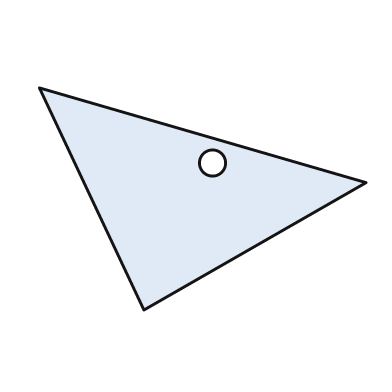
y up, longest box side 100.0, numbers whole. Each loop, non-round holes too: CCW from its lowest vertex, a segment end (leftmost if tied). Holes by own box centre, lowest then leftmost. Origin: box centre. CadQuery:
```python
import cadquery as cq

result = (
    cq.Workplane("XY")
    .moveTo(-18.0, -34.0)
    .lineTo(50.0, 5.0)
    .lineTo(-50.0, 34.0)
    .close()
    .moveTo(3.0, 11.0)
    .circle(4.0)
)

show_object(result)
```